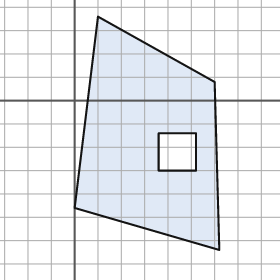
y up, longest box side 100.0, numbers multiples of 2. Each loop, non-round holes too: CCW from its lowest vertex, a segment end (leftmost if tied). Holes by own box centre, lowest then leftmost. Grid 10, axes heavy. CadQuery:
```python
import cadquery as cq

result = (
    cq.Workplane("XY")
    .moveTo(62.0, -64.0)
    .lineTo(60.0, 8.0)
    .lineTo(10.0, 36.0)
    .lineTo(0.0, -46.0)
    .close()
    .moveTo(36.0, -30.0)
    .lineTo(52.0, -30.0)
    .lineTo(52.0, -14.0)
    .lineTo(36.0, -14.0)
    .close()
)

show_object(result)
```